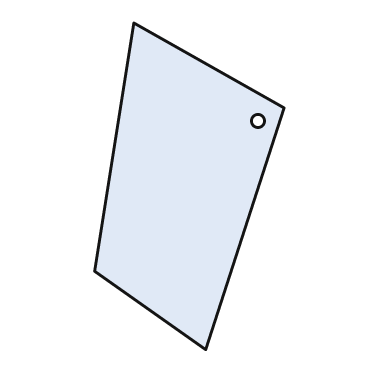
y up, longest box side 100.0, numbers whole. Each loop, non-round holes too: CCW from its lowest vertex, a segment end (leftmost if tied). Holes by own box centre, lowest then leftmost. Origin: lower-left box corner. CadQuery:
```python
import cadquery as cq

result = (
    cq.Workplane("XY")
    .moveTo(34.0, 0.0)
    .lineTo(58.0, 74.0)
    .lineTo(12.0, 100.0)
    .lineTo(0.0, 24.0)
    .close()
    .moveTo(50.0, 70.0)
    .circle(2.0)
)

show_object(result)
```